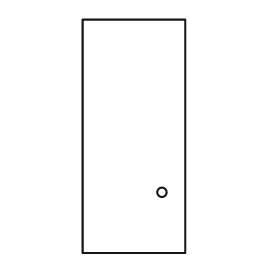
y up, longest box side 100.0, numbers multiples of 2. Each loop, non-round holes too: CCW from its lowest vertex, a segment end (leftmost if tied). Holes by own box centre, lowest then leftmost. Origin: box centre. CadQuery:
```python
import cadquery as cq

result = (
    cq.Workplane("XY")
    .moveTo(-22.0, -50.0)
    .lineTo(22.0, -50.0)
    .lineTo(22.0, 50.0)
    .lineTo(-22.0, 50.0)
    .close()
    .moveTo(12.0, -24.0)
    .circle(2.0)
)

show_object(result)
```